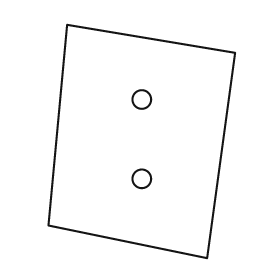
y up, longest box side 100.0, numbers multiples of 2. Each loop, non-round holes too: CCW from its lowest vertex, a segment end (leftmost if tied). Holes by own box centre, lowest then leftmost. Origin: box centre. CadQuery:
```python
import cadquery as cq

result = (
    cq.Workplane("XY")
    .moveTo(28.0, -50.0)
    .lineTo(40.0, 38.0)
    .lineTo(-32.0, 50.0)
    .lineTo(-40.0, -36.0)
    .close()
    .moveTo(0.0, -16.0)
    .circle(4.0)
    .moveTo(0.0, 18.0)
    .circle(4.0)
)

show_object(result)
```